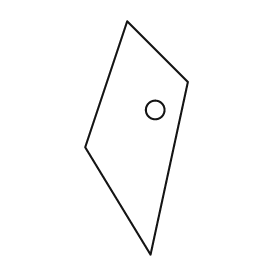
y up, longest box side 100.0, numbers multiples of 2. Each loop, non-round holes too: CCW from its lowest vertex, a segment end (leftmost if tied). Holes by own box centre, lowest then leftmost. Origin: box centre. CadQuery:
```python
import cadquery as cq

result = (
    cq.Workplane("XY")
    .moveTo(6.0, -50.0)
    .lineTo(22.0, 24.0)
    .lineTo(-4.0, 50.0)
    .lineTo(-22.0, -4.0)
    .close()
    .moveTo(8.0, 12.0)
    .circle(4.0)
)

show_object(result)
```